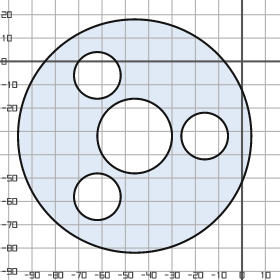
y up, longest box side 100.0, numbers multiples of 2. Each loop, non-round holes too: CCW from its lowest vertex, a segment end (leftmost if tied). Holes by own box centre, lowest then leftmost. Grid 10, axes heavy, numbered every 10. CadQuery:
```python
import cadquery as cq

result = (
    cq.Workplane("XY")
    .moveTo(-46.0, -32.0)
    .circle(50.0)
    .moveTo(-62.0, -58.0)
    .circle(10.0)
    .moveTo(-46.0, -32.0)
    .circle(16.0)
    .moveTo(-16.0, -32.0)
    .circle(10.0)
    .moveTo(-62.0, -6.0)
    .circle(10.0)
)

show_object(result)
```